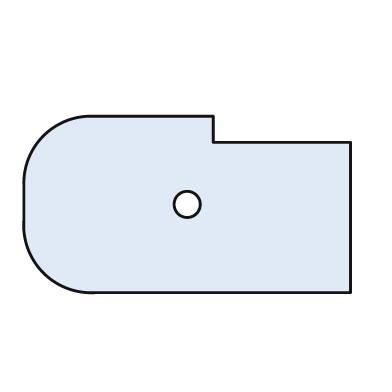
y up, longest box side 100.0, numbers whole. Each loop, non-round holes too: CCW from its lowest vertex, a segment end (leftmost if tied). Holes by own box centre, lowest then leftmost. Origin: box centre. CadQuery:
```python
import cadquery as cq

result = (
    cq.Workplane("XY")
    .moveTo(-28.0, -27.0)
    .lineTo(50.0, -27.0)
    .lineTo(50.0, 19.0)
    .lineTo(8.0, 19.0)
    .lineTo(8.0, 27.0)
    .lineTo(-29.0, 27.0)
    .threePointArc((-44.0, 21.0), (-50.0, 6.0))
    .lineTo(-50.0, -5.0)
    .threePointArc((-44.0, -21.0), (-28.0, -27.0))
    .close()
    .moveTo(0.0, 0.0)
    .circle(4.0)
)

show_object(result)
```